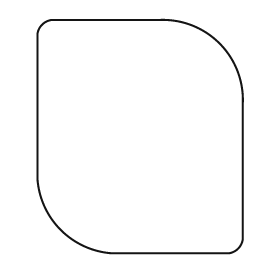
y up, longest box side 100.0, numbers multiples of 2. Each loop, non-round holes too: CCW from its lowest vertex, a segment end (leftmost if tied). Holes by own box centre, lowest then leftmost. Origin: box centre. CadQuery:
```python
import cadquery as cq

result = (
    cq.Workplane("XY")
    .moveTo(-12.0, -50.0)
    .lineTo(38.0, -50.0)
    .threePointArc((42.0, -48.0), (44.0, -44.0))
    .lineTo(44.0, 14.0)
    .threePointArc((34.0, 40.0), (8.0, 50.0))
    .lineTo(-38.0, 50.0)
    .threePointArc((-42.0, 48.0), (-44.0, 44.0))
    .lineTo(-44.0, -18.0)
    .threePointArc((-34.0, -40.0), (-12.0, -50.0))
    .close()
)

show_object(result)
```